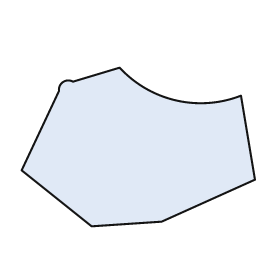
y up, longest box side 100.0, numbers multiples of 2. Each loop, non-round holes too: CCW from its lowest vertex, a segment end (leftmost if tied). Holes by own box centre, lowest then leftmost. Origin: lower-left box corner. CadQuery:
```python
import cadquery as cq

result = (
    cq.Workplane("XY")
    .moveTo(30.0, 0.0)
    .lineTo(60.0, 2.0)
    .lineTo(100.0, 20.0)
    .lineTo(94.0, 56.0)
    .threePointArc((66.0, 54.0), (42.0, 68.0))
    .lineTo(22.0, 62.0)
    .threePointArc((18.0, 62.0), (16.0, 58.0))
    .lineTo(0.0, 24.0)
    .close()
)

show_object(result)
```